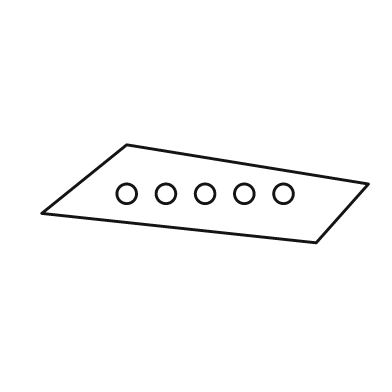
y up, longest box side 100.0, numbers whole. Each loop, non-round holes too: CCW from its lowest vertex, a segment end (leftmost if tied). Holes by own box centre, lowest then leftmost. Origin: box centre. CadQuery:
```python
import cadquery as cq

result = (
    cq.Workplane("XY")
    .moveTo(34.0, -15.0)
    .lineTo(50.0, 3.0)
    .lineTo(-24.0, 15.0)
    .lineTo(-50.0, -6.0)
    .close()
    .moveTo(-24.0, 0.0)
    .circle(3.0)
    .moveTo(-12.0, 0.0)
    .circle(3.0)
    .moveTo(0.0, 0.0)
    .circle(3.0)
    .moveTo(12.0, 0.0)
    .circle(3.0)
    .moveTo(24.0, 0.0)
    .circle(3.0)
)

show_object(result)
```